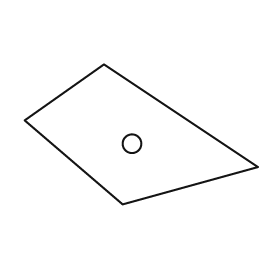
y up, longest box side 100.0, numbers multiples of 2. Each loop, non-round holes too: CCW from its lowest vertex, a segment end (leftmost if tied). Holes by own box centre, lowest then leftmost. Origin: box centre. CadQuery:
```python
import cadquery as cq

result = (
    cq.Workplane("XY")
    .moveTo(-8.0, -30.0)
    .lineTo(50.0, -14.0)
    .lineTo(-16.0, 30.0)
    .lineTo(-50.0, 6.0)
    .close()
    .moveTo(-4.0, -4.0)
    .circle(4.0)
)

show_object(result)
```